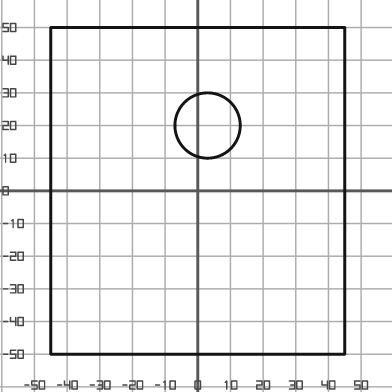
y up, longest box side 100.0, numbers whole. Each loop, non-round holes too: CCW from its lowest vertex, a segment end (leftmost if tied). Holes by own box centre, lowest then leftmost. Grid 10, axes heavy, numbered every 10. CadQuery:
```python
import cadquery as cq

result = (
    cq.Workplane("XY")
    .moveTo(-45.0, -50.0)
    .lineTo(45.0, -50.0)
    .lineTo(45.0, 50.0)
    .lineTo(-45.0, 50.0)
    .close()
    .moveTo(3.0, 20.0)
    .circle(10.0)
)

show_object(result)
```